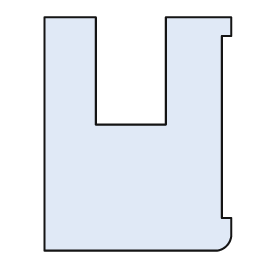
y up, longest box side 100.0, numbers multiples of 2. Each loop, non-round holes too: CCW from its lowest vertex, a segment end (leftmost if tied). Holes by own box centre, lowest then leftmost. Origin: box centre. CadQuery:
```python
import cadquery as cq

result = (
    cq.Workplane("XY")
    .moveTo(-40.0, -50.0)
    .lineTo(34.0, -50.0)
    .threePointArc((38.0, -48.0), (40.0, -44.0))
    .lineTo(40.0, -36.0)
    .lineTo(36.0, -36.0)
    .lineTo(36.0, 42.0)
    .lineTo(40.0, 42.0)
    .lineTo(40.0, 50.0)
    .lineTo(12.0, 50.0)
    .lineTo(12.0, 4.0)
    .lineTo(-18.0, 4.0)
    .lineTo(-18.0, 50.0)
    .lineTo(-40.0, 50.0)
    .close()
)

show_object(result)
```